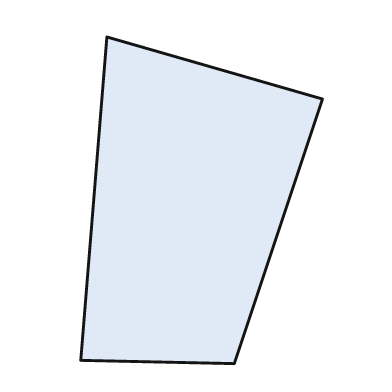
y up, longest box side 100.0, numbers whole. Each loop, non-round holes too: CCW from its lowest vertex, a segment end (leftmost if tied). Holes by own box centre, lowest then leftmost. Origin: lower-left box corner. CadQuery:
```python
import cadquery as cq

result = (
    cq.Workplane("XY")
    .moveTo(47.0, 0.0)
    .lineTo(74.0, 81.0)
    .lineTo(8.0, 100.0)
    .lineTo(0.0, 1.0)
    .close()
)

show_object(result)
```